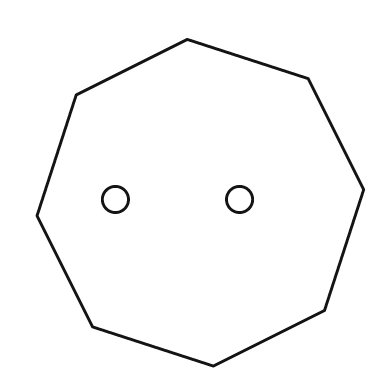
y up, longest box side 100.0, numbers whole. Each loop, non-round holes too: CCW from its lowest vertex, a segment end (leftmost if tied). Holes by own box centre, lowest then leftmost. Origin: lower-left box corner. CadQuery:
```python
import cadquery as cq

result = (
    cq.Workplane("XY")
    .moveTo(54.0, 0.0)
    .lineTo(88.0, 17.0)
    .lineTo(100.0, 54.0)
    .lineTo(83.0, 88.0)
    .lineTo(46.0, 100.0)
    .lineTo(12.0, 83.0)
    .lineTo(0.0, 46.0)
    .lineTo(17.0, 12.0)
    .close()
    .moveTo(24.0, 51.0)
    .circle(4.0)
    .moveTo(62.0, 51.0)
    .circle(4.0)
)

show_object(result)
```